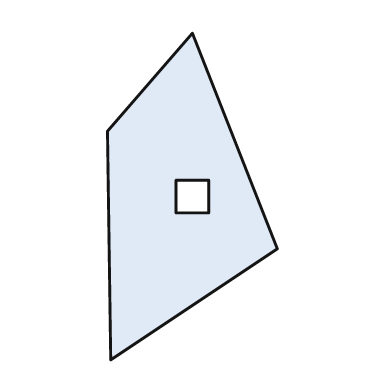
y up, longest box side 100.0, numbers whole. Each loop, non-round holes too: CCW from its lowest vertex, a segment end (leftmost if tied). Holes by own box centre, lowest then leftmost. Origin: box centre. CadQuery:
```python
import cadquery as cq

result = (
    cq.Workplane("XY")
    .moveTo(-25.0, -50.0)
    .lineTo(26.0, -16.0)
    .lineTo(0.0, 50.0)
    .lineTo(-26.0, 20.0)
    .close()
    .moveTo(-5.0, -5.0)
    .lineTo(5.0, -5.0)
    .lineTo(5.0, 5.0)
    .lineTo(-5.0, 5.0)
    .close()
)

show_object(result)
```